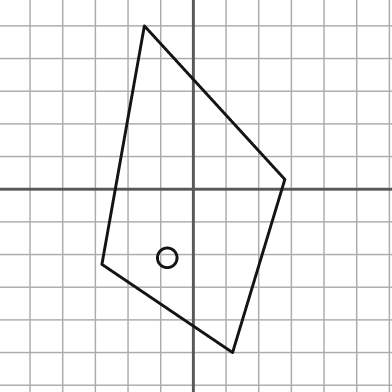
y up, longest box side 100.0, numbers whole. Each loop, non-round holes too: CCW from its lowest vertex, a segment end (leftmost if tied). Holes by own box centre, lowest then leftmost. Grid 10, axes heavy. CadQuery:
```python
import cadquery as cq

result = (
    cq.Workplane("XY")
    .moveTo(12.0, -50.0)
    .lineTo(28.0, 3.0)
    .lineTo(-15.0, 50.0)
    .lineTo(-28.0, -23.0)
    .close()
    .moveTo(-8.0, -21.0)
    .circle(3.0)
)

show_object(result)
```